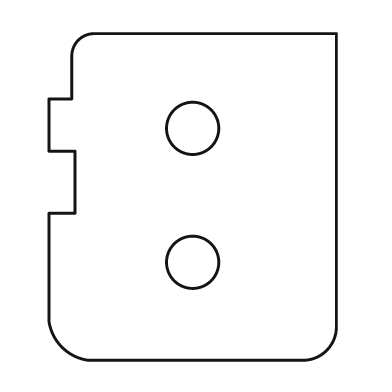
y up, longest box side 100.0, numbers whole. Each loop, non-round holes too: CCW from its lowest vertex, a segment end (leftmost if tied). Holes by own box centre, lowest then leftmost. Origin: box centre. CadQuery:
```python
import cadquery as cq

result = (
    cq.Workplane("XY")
    .moveTo(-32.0, -50.0)
    .lineTo(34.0, -50.0)
    .threePointArc((41.0, -47.0), (44.0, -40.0))
    .lineTo(44.0, 50.0)
    .lineTo(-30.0, 50.0)
    .threePointArc((-35.0, 48.0), (-37.0, 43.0))
    .lineTo(-37.0, 30.0)
    .lineTo(-44.0, 30.0)
    .lineTo(-44.0, 14.0)
    .lineTo(-36.0, 14.0)
    .lineTo(-36.0, -5.0)
    .lineTo(-44.0, -5.0)
    .lineTo(-44.0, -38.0)
    .threePointArc((-40.0, -46.0), (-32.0, -50.0))
    .close()
    .moveTo(0.0, -20.0)
    .circle(8.0)
    .moveTo(0.0, 21.0)
    .circle(8.0)
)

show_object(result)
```